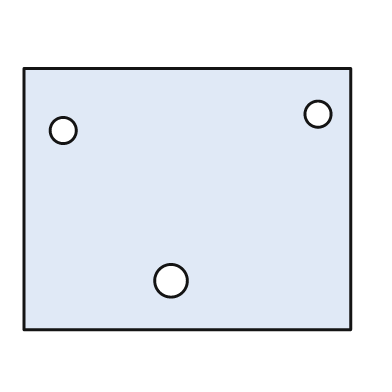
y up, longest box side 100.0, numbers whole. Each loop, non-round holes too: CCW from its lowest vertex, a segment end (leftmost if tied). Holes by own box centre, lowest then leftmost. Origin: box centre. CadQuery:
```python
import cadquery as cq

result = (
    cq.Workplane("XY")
    .moveTo(-50.0, -40.0)
    .lineTo(50.0, -40.0)
    .lineTo(50.0, 40.0)
    .lineTo(-50.0, 40.0)
    .close()
    .moveTo(-5.0, -25.0)
    .circle(5.0)
    .moveTo(-38.0, 21.0)
    .circle(4.0)
    .moveTo(40.0, 26.0)
    .circle(4.0)
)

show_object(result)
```